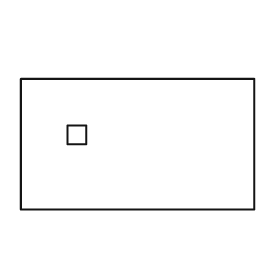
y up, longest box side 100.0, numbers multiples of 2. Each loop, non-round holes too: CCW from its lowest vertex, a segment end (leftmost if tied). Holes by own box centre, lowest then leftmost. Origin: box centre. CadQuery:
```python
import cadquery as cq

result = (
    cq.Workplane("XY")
    .moveTo(-50.0, -28.0)
    .lineTo(50.0, -28.0)
    .lineTo(50.0, 28.0)
    .lineTo(-50.0, 28.0)
    .close()
    .moveTo(-30.0, 0.0)
    .lineTo(-22.0, 0.0)
    .lineTo(-22.0, 8.0)
    .lineTo(-30.0, 8.0)
    .close()
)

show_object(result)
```